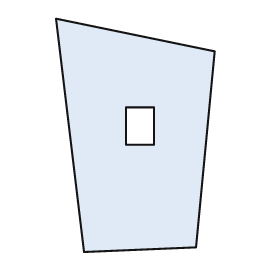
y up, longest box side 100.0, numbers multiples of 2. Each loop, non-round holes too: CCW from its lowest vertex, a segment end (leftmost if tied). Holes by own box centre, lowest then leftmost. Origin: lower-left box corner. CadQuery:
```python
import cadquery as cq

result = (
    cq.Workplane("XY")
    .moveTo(12.0, 0.0)
    .lineTo(60.0, 2.0)
    .lineTo(68.0, 86.0)
    .lineTo(0.0, 100.0)
    .close()
    .moveTo(30.0, 46.0)
    .lineTo(42.0, 46.0)
    .lineTo(42.0, 62.0)
    .lineTo(30.0, 62.0)
    .close()
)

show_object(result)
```